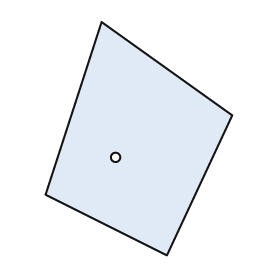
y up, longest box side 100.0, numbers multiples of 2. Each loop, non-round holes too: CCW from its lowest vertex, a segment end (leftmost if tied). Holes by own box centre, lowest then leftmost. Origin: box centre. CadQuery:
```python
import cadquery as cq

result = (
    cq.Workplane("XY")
    .moveTo(12.0, -50.0)
    .lineTo(40.0, 10.0)
    .lineTo(-16.0, 50.0)
    .lineTo(-40.0, -24.0)
    .close()
    .moveTo(-10.0, -8.0)
    .circle(2.0)
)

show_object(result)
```